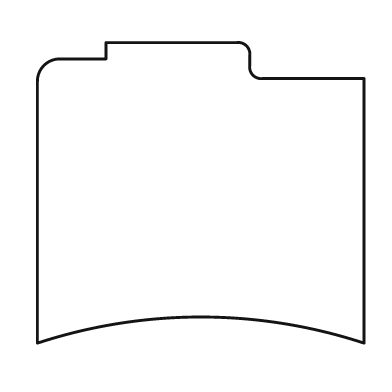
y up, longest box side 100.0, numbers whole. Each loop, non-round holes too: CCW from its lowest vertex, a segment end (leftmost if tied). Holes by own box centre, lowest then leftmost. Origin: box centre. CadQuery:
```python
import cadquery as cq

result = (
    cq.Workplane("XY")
    .moveTo(-50.0, -46.0)
    .threePointArc((0.0, -38.0), (50.0, -46.0))
    .lineTo(50.0, 35.0)
    .lineTo(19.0, 35.0)
    .threePointArc((16.0, 36.0), (15.0, 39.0))
    .lineTo(15.0, 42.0)
    .threePointArc((14.0, 45.0), (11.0, 46.0))
    .lineTo(-29.0, 46.0)
    .lineTo(-29.0, 41.0)
    .lineTo(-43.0, 41.0)
    .threePointArc((-48.0, 39.0), (-50.0, 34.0))
    .close()
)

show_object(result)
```